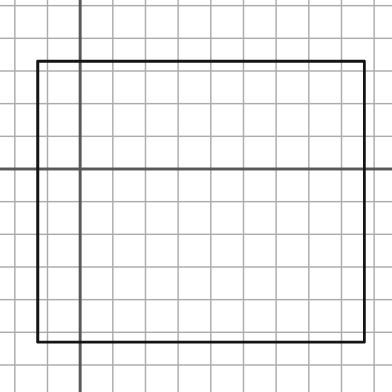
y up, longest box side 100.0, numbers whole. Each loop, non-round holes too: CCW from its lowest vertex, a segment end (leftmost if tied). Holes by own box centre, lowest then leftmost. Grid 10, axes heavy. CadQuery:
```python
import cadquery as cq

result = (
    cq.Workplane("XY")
    .moveTo(-13.0, -53.0)
    .lineTo(87.0, -53.0)
    .lineTo(87.0, 33.0)
    .lineTo(-13.0, 33.0)
    .close()
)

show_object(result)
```